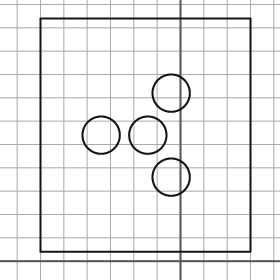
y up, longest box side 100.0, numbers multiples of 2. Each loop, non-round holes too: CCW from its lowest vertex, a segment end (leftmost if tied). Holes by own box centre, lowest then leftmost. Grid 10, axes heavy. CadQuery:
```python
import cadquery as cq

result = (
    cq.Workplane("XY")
    .moveTo(-60.0, 4.0)
    .lineTo(30.0, 4.0)
    .lineTo(30.0, 104.0)
    .lineTo(-60.0, 104.0)
    .close()
    .moveTo(-4.0, 36.0)
    .circle(8.0)
    .moveTo(-34.0, 54.0)
    .circle(8.0)
    .moveTo(-14.0, 54.0)
    .circle(8.0)
    .moveTo(-4.0, 72.0)
    .circle(8.0)
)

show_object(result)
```